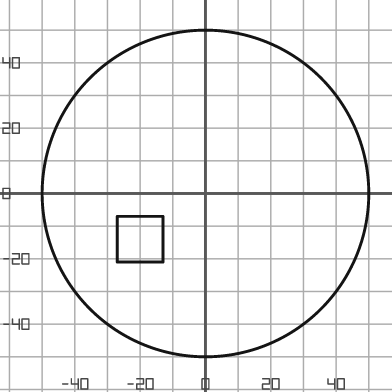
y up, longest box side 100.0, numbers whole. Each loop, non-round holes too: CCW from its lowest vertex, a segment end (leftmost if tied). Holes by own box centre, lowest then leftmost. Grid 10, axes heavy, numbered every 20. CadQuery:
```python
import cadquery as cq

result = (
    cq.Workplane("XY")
    .moveTo(0.0, 0.0)
    .circle(50.0)
    .moveTo(-27.0, -21.0)
    .lineTo(-13.0, -21.0)
    .lineTo(-13.0, -7.0)
    .lineTo(-27.0, -7.0)
    .close()
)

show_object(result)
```